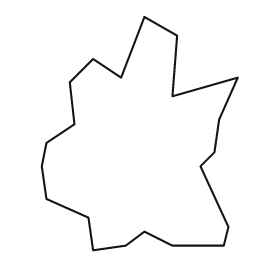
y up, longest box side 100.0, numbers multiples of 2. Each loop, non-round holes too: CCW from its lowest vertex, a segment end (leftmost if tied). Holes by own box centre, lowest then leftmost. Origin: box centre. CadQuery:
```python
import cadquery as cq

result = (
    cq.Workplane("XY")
    .moveTo(-20.0, -50.0)
    .lineTo(-6.0, -48.0)
    .lineTo(2.0, -42.0)
    .lineTo(14.0, -48.0)
    .lineTo(36.0, -48.0)
    .lineTo(38.0, -40.0)
    .lineTo(26.0, -14.0)
    .lineTo(32.0, -8.0)
    .lineTo(34.0, 6.0)
    .lineTo(42.0, 24.0)
    .lineTo(14.0, 16.0)
    .lineTo(16.0, 42.0)
    .lineTo(2.0, 50.0)
    .lineTo(-8.0, 24.0)
    .lineTo(-20.0, 32.0)
    .lineTo(-30.0, 22.0)
    .lineTo(-28.0, 4.0)
    .lineTo(-40.0, -4.0)
    .lineTo(-42.0, -14.0)
    .lineTo(-40.0, -28.0)
    .lineTo(-22.0, -36.0)
    .close()
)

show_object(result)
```